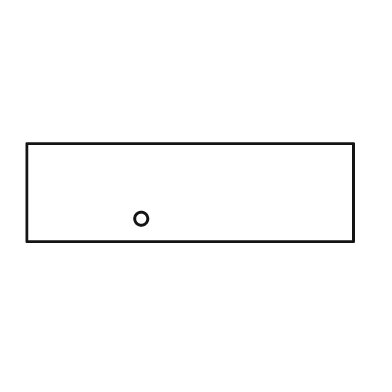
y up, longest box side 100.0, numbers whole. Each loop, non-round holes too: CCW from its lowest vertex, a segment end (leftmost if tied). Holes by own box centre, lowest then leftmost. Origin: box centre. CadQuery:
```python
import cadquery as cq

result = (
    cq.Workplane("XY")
    .moveTo(-50.0, -15.0)
    .lineTo(50.0, -15.0)
    .lineTo(50.0, 15.0)
    .lineTo(-50.0, 15.0)
    .close()
    .moveTo(-15.0, -8.0)
    .circle(2.0)
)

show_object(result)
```